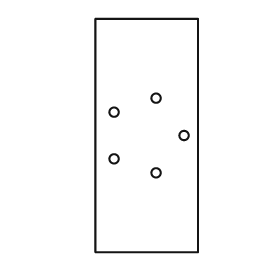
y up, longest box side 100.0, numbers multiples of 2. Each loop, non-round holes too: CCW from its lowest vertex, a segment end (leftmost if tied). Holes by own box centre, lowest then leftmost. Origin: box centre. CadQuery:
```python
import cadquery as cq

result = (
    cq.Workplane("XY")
    .moveTo(-22.0, -50.0)
    .lineTo(22.0, -50.0)
    .lineTo(22.0, 50.0)
    .lineTo(-22.0, 50.0)
    .close()
    .moveTo(4.0, -16.0)
    .circle(2.0)
    .moveTo(-14.0, -10.0)
    .circle(2.0)
    .moveTo(16.0, 0.0)
    .circle(2.0)
    .moveTo(-14.0, 10.0)
    .circle(2.0)
    .moveTo(4.0, 16.0)
    .circle(2.0)
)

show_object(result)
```